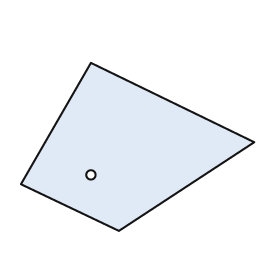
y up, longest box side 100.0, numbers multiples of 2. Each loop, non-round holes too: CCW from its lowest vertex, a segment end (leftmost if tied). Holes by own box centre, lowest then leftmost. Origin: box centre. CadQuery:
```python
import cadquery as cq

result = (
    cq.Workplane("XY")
    .moveTo(-8.0, -36.0)
    .lineTo(50.0, 2.0)
    .lineTo(-20.0, 36.0)
    .lineTo(-50.0, -16.0)
    .close()
    .moveTo(-20.0, -12.0)
    .circle(2.0)
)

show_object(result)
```